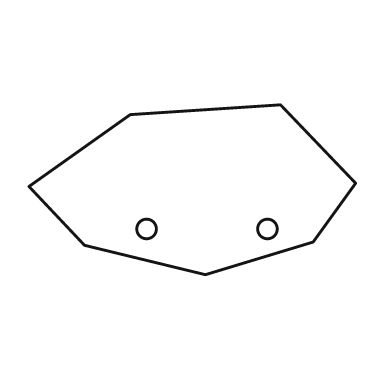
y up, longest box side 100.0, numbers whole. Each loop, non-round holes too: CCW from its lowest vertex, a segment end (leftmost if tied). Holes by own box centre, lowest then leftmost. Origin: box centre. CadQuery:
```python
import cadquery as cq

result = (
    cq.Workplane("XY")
    .moveTo(4.0, -26.0)
    .lineTo(37.0, -16.0)
    .lineTo(50.0, 2.0)
    .lineTo(27.0, 26.0)
    .lineTo(-19.0, 23.0)
    .lineTo(-50.0, 1.0)
    .lineTo(-33.0, -17.0)
    .close()
    .moveTo(-14.0, -12.0)
    .circle(3.0)
    .moveTo(23.0, -12.0)
    .circle(3.0)
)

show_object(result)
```